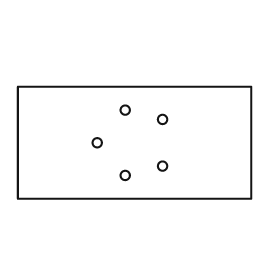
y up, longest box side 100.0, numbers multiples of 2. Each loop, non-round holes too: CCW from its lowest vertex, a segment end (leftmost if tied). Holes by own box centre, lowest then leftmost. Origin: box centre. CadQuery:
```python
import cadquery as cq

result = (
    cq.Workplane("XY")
    .moveTo(-50.0, -24.0)
    .lineTo(50.0, -24.0)
    .lineTo(50.0, 24.0)
    .lineTo(-50.0, 24.0)
    .close()
    .moveTo(-4.0, -14.0)
    .circle(2.0)
    .moveTo(12.0, -10.0)
    .circle(2.0)
    .moveTo(-16.0, 0.0)
    .circle(2.0)
    .moveTo(12.0, 10.0)
    .circle(2.0)
    .moveTo(-4.0, 14.0)
    .circle(2.0)
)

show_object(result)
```